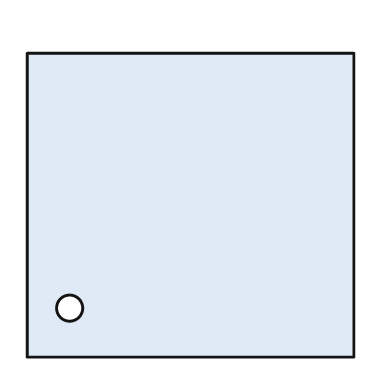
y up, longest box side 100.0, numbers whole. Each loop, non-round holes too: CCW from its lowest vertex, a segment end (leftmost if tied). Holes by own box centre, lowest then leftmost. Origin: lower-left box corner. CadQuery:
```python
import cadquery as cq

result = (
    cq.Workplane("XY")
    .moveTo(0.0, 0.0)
    .lineTo(100.0, 0.0)
    .lineTo(100.0, 93.0)
    .lineTo(0.0, 93.0)
    .close()
    .moveTo(13.0, 15.0)
    .circle(4.0)
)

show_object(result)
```